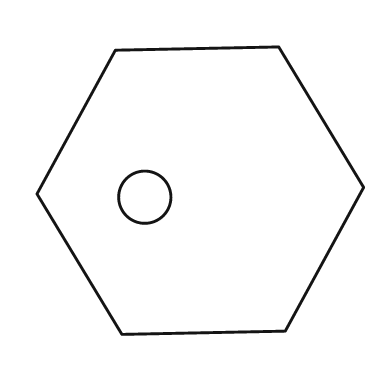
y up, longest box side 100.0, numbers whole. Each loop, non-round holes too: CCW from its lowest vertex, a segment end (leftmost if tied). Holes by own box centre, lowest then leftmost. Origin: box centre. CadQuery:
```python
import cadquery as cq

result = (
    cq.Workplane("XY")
    .moveTo(-24.0, -44.0)
    .lineTo(26.0, -43.0)
    .lineTo(50.0, 1.0)
    .lineTo(24.0, 44.0)
    .lineTo(-26.0, 43.0)
    .lineTo(-50.0, -1.0)
    .close()
    .moveTo(-17.0, -2.0)
    .circle(8.0)
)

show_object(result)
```